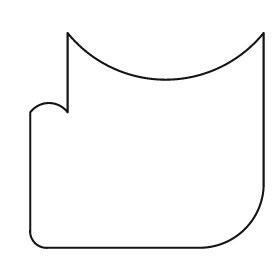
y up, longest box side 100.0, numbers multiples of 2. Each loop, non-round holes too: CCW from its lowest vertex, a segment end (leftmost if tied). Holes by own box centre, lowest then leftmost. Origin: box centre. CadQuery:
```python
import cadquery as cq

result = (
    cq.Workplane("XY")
    .moveTo(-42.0, -46.0)
    .lineTo(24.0, -46.0)
    .threePointArc((42.0, -38.0), (50.0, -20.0))
    .lineTo(50.0, 46.0)
    .threePointArc((8.0, 26.0), (-34.0, 46.0))
    .lineTo(-34.0, 12.0)
    .threePointArc((-42.0, 16.0), (-50.0, 12.0))
    .lineTo(-50.0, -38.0)
    .threePointArc((-48.0, -44.0), (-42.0, -46.0))
    .close()
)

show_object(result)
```